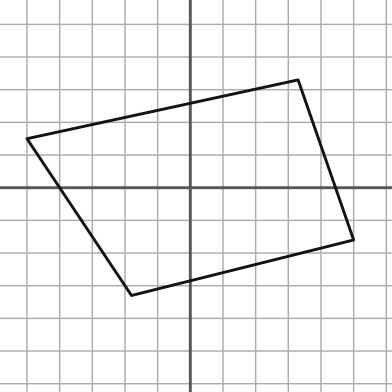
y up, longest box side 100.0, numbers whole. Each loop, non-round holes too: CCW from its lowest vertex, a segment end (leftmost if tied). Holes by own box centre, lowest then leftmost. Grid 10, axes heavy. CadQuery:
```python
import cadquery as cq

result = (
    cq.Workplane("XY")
    .moveTo(-18.0, -33.0)
    .lineTo(50.0, -16.0)
    .lineTo(33.0, 33.0)
    .lineTo(-50.0, 15.0)
    .close()
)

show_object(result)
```